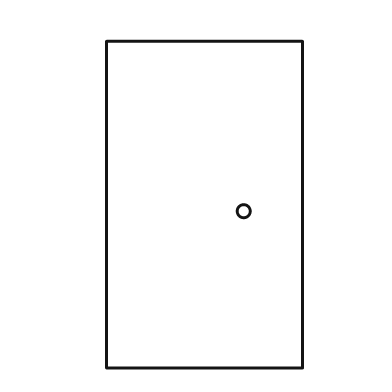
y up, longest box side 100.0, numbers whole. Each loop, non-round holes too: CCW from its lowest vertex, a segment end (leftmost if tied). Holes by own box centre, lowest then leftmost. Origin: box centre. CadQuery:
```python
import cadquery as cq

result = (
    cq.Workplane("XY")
    .moveTo(-30.0, -50.0)
    .lineTo(30.0, -50.0)
    .lineTo(30.0, 50.0)
    .lineTo(-30.0, 50.0)
    .close()
    .moveTo(12.0, -2.0)
    .circle(2.0)
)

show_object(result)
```